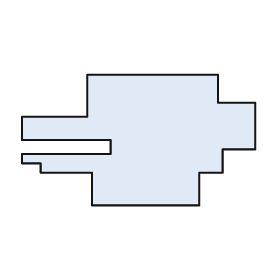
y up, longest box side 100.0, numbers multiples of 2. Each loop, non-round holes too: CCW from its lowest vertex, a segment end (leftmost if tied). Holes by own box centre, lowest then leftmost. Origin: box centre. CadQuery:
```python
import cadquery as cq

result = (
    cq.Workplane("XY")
    .moveTo(-20.0, -28.0)
    .lineTo(26.0, -28.0)
    .lineTo(26.0, -14.0)
    .lineTo(36.0, -14.0)
    .lineTo(36.0, -4.0)
    .lineTo(50.0, -4.0)
    .lineTo(50.0, 16.0)
    .lineTo(34.0, 16.0)
    .lineTo(34.0, 28.0)
    .lineTo(-22.0, 28.0)
    .lineTo(-22.0, 10.0)
    .lineTo(-50.0, 10.0)
    .lineTo(-50.0, 0.0)
    .lineTo(-12.0, 0.0)
    .lineTo(-12.0, -6.0)
    .lineTo(-50.0, -6.0)
    .lineTo(-50.0, -10.0)
    .lineTo(-42.0, -10.0)
    .lineTo(-42.0, -14.0)
    .lineTo(-20.0, -14.0)
    .close()
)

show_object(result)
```